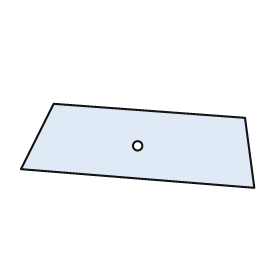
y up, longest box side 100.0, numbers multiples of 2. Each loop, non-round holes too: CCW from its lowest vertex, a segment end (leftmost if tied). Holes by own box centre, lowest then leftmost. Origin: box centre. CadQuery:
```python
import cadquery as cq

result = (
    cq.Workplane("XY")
    .moveTo(50.0, -18.0)
    .lineTo(46.0, 12.0)
    .lineTo(-36.0, 18.0)
    .lineTo(-50.0, -10.0)
    .close()
    .moveTo(0.0, 0.0)
    .circle(2.0)
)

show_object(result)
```